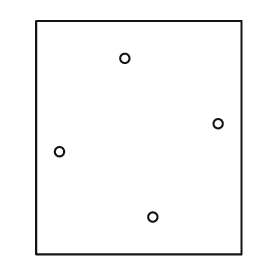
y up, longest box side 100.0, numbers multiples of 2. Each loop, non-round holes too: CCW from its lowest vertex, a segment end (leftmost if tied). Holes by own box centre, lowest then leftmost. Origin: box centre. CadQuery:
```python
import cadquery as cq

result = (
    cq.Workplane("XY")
    .moveTo(-44.0, -50.0)
    .lineTo(44.0, -50.0)
    .lineTo(44.0, 50.0)
    .lineTo(-44.0, 50.0)
    .close()
    .moveTo(6.0, -34.0)
    .circle(2.0)
    .moveTo(-34.0, -6.0)
    .circle(2.0)
    .moveTo(34.0, 6.0)
    .circle(2.0)
    .moveTo(-6.0, 34.0)
    .circle(2.0)
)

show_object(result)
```